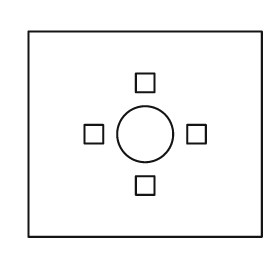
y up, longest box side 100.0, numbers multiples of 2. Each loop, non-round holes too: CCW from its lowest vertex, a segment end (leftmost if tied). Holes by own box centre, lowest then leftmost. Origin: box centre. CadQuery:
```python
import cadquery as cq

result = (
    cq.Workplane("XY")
    .moveTo(-50.0, -44.0)
    .lineTo(50.0, -44.0)
    .lineTo(50.0, 44.0)
    .lineTo(-50.0, 44.0)
    .close()
    .moveTo(-4.0, -26.0)
    .lineTo(4.0, -26.0)
    .lineTo(4.0, -18.0)
    .lineTo(-4.0, -18.0)
    .close()
    .moveTo(-26.0, -4.0)
    .lineTo(-18.0, -4.0)
    .lineTo(-18.0, 4.0)
    .lineTo(-26.0, 4.0)
    .close()
    .moveTo(0.0, 0.0)
    .circle(12.0)
    .moveTo(18.0, -4.0)
    .lineTo(26.0, -4.0)
    .lineTo(26.0, 4.0)
    .lineTo(18.0, 4.0)
    .close()
    .moveTo(-4.0, 18.0)
    .lineTo(4.0, 18.0)
    .lineTo(4.0, 26.0)
    .lineTo(-4.0, 26.0)
    .close()
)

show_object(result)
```